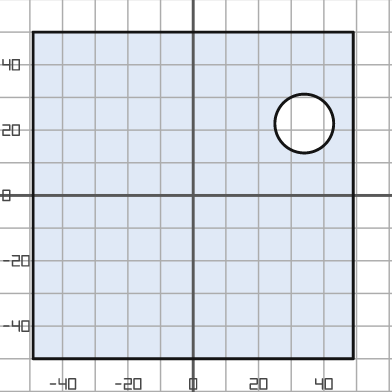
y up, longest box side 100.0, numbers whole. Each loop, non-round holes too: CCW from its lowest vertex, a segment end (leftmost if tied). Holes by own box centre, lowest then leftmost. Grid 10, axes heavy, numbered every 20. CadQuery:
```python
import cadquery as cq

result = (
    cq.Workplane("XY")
    .moveTo(-49.0, -50.0)
    .lineTo(49.0, -50.0)
    .lineTo(49.0, 50.0)
    .lineTo(-49.0, 50.0)
    .close()
    .moveTo(34.0, 22.0)
    .circle(9.0)
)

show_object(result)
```